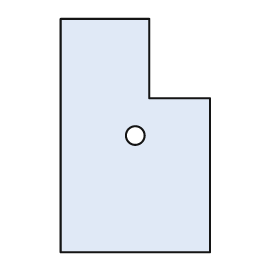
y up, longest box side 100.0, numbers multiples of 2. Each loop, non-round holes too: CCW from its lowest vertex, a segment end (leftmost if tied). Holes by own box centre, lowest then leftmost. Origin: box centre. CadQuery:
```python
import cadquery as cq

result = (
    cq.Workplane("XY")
    .moveTo(-32.0, -50.0)
    .lineTo(32.0, -50.0)
    .lineTo(32.0, 16.0)
    .lineTo(6.0, 16.0)
    .lineTo(6.0, 50.0)
    .lineTo(-32.0, 50.0)
    .close()
    .moveTo(0.0, 0.0)
    .circle(4.0)
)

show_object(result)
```